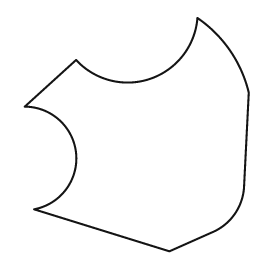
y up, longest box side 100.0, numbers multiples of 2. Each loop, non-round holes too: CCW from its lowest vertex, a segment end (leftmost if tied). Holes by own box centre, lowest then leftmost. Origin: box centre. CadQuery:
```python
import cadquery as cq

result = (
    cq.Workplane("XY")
    .moveTo(14.0, -50.0)
    .lineTo(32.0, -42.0)
    .threePointArc((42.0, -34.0), (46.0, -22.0))
    .lineTo(48.0, 18.0)
    .threePointArc((40.0, 36.0), (26.0, 50.0))
    .threePointArc((6.0, 24.0), (-26.0, 32.0))
    .lineTo(-48.0, 12.0)
    .threePointArc((-26.0, -8.0), (-44.0, -32.0))
    .close()
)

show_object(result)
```